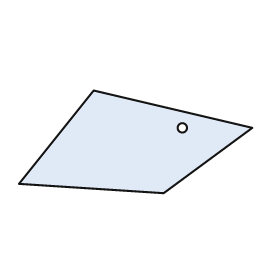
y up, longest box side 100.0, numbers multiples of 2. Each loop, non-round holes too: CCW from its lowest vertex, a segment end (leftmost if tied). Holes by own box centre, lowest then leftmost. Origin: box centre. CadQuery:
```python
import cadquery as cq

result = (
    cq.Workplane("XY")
    .moveTo(12.0, -22.0)
    .lineTo(50.0, 6.0)
    .lineTo(-18.0, 22.0)
    .lineTo(-50.0, -18.0)
    .close()
    .moveTo(20.0, 6.0)
    .circle(2.0)
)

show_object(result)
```